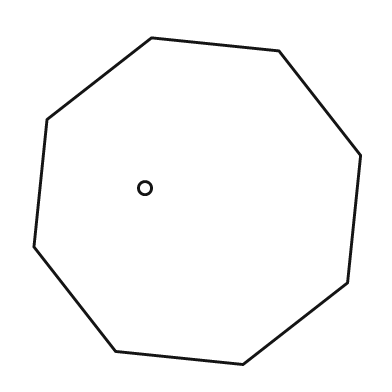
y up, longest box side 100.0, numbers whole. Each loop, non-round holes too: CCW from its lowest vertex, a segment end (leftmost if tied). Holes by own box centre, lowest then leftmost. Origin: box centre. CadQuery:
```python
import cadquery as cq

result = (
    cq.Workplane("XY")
    .moveTo(14.0, -50.0)
    .lineTo(46.0, -25.0)
    .lineTo(50.0, 14.0)
    .lineTo(25.0, 46.0)
    .lineTo(-14.0, 50.0)
    .lineTo(-46.0, 25.0)
    .lineTo(-50.0, -14.0)
    .lineTo(-25.0, -46.0)
    .close()
    .moveTo(-16.0, 4.0)
    .circle(2.0)
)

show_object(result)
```